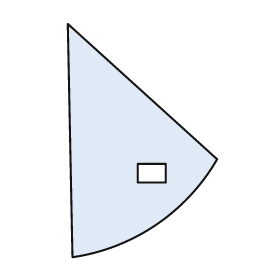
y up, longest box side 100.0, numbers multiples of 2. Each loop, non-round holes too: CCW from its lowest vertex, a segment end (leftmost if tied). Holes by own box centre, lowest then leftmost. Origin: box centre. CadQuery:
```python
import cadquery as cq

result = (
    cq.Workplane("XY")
    .moveTo(-30.0, -50.0)
    .threePointArc((6.0, -36.0), (32.0, -8.0))
    .lineTo(-32.0, 50.0)
    .close()
    .moveTo(-2.0, -18.0)
    .lineTo(10.0, -18.0)
    .lineTo(10.0, -10.0)
    .lineTo(-2.0, -10.0)
    .close()
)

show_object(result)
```